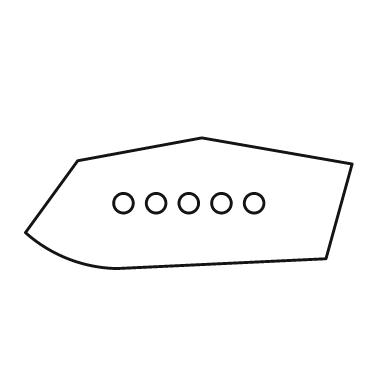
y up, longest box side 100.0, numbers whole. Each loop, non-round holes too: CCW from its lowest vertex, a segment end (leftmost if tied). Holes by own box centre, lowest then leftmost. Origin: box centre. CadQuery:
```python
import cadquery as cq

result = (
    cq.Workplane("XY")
    .moveTo(-22.0, -20.0)
    .lineTo(42.0, -17.0)
    .lineTo(50.0, 12.0)
    .lineTo(4.0, 20.0)
    .lineTo(-34.0, 13.0)
    .lineTo(-50.0, -9.0)
    .threePointArc((-37.0, -17.0), (-22.0, -20.0))
    .close()
    .moveTo(-20.0, 0.0)
    .circle(3.0)
    .moveTo(-10.0, 0.0)
    .circle(3.0)
    .moveTo(0.0, 0.0)
    .circle(3.0)
    .moveTo(10.0, 0.0)
    .circle(3.0)
    .moveTo(20.0, 0.0)
    .circle(3.0)
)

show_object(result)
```